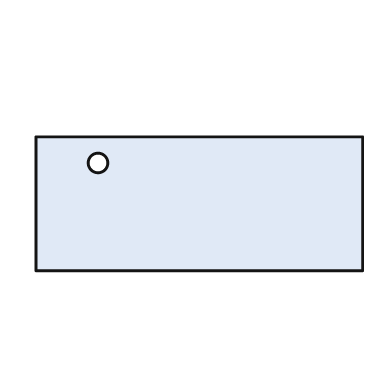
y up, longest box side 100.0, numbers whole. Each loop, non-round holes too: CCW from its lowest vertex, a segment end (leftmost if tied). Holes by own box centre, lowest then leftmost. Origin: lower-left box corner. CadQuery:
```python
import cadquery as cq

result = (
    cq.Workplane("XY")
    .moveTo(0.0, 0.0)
    .lineTo(100.0, 0.0)
    .lineTo(100.0, 41.0)
    .lineTo(0.0, 41.0)
    .close()
    .moveTo(19.0, 33.0)
    .circle(3.0)
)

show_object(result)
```